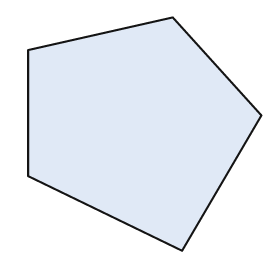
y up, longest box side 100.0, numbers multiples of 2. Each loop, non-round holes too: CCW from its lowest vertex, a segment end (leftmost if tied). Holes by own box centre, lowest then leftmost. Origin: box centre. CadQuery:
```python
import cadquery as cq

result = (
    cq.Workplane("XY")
    .moveTo(16.0, -50.0)
    .lineTo(50.0, 8.0)
    .lineTo(12.0, 50.0)
    .lineTo(-50.0, 36.0)
    .lineTo(-50.0, -18.0)
    .close()
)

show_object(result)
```